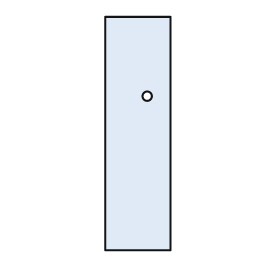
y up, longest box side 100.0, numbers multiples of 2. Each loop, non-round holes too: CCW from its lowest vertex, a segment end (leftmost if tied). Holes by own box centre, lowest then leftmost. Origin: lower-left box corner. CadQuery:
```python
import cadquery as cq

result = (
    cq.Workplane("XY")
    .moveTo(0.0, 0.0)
    .lineTo(28.0, 0.0)
    .lineTo(28.0, 100.0)
    .lineTo(0.0, 100.0)
    .close()
    .moveTo(18.0, 66.0)
    .circle(2.0)
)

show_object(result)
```